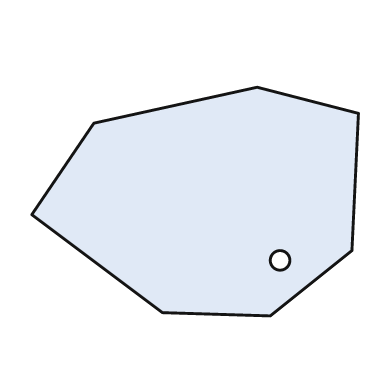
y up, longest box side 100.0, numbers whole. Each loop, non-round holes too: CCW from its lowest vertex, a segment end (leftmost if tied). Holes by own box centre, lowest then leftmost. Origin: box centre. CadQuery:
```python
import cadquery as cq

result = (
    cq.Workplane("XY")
    .moveTo(23.0, -35.0)
    .lineTo(48.0, -15.0)
    .lineTo(50.0, 27.0)
    .lineTo(19.0, 35.0)
    .lineTo(-31.0, 24.0)
    .lineTo(-50.0, -4.0)
    .lineTo(-10.0, -34.0)
    .close()
    .moveTo(26.0, -18.0)
    .circle(3.0)
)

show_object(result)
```